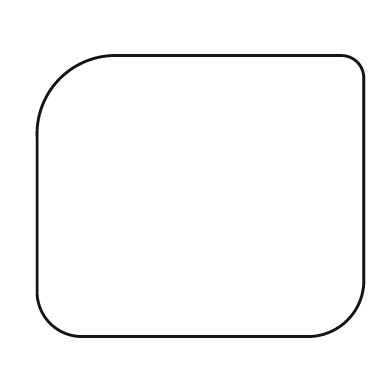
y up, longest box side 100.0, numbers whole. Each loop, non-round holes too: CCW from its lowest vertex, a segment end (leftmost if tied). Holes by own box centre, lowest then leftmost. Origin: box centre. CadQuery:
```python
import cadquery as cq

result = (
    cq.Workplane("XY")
    .moveTo(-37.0, -43.0)
    .lineTo(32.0, -43.0)
    .threePointArc((45.0, -38.0), (50.0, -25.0))
    .lineTo(50.0, 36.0)
    .threePointArc((48.0, 41.0), (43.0, 43.0))
    .lineTo(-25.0, 43.0)
    .threePointArc((-43.0, 36.0), (-50.0, 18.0))
    .lineTo(-50.0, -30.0)
    .threePointArc((-46.0, -39.0), (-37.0, -43.0))
    .close()
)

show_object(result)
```